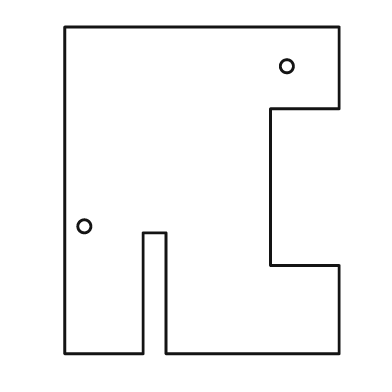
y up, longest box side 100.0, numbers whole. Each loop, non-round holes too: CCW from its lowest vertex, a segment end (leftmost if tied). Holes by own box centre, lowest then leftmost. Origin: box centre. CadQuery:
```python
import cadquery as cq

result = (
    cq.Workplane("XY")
    .moveTo(-42.0, -50.0)
    .lineTo(-18.0, -50.0)
    .lineTo(-18.0, -13.0)
    .lineTo(-11.0, -13.0)
    .lineTo(-11.0, -50.0)
    .lineTo(42.0, -50.0)
    .lineTo(42.0, -23.0)
    .lineTo(21.0, -23.0)
    .lineTo(21.0, 25.0)
    .lineTo(42.0, 25.0)
    .lineTo(42.0, 50.0)
    .lineTo(-42.0, 50.0)
    .close()
    .moveTo(-36.0, -11.0)
    .circle(2.0)
    .moveTo(26.0, 38.0)
    .circle(2.0)
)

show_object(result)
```